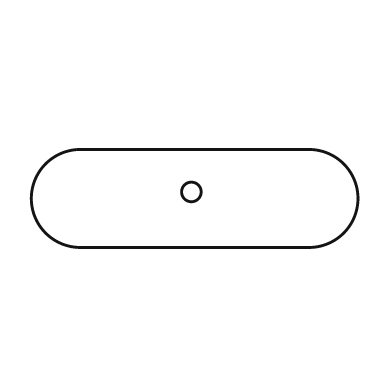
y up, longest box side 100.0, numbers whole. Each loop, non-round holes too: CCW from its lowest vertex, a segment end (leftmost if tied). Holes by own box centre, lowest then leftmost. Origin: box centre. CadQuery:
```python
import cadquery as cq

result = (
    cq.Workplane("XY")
    .moveTo(-35.0, -15.0)
    .lineTo(35.0, -15.0)
    .threePointArc((50.0, 0.0), (35.0, 15.0))
    .lineTo(-35.0, 15.0)
    .threePointArc((-50.0, 0.0), (-35.0, -15.0))
    .close()
    .moveTo(-1.0, 2.0)
    .circle(3.0)
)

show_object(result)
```